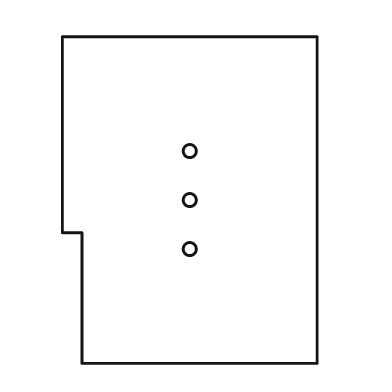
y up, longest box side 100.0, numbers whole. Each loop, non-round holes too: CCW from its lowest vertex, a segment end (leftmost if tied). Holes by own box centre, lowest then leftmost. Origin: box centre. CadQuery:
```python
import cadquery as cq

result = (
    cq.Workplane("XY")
    .moveTo(-33.0, -50.0)
    .lineTo(39.0, -50.0)
    .lineTo(39.0, 50.0)
    .lineTo(-39.0, 50.0)
    .lineTo(-39.0, -10.0)
    .lineTo(-33.0, -10.0)
    .close()
    .moveTo(0.0, -15.0)
    .circle(2.0)
    .moveTo(0.0, 0.0)
    .circle(2.0)
    .moveTo(0.0, 15.0)
    .circle(2.0)
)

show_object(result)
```